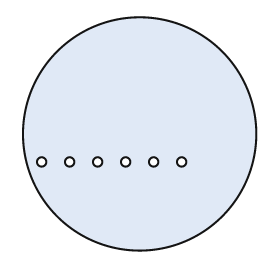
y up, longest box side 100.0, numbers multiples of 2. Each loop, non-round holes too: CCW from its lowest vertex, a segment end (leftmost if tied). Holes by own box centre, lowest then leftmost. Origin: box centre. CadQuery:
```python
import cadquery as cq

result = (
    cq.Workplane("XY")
    .moveTo(0.0, 0.0)
    .circle(50.0)
    .moveTo(-42.0, -12.0)
    .circle(2.0)
    .moveTo(-30.0, -12.0)
    .circle(2.0)
    .moveTo(-18.0, -12.0)
    .circle(2.0)
    .moveTo(-6.0, -12.0)
    .circle(2.0)
    .moveTo(6.0, -12.0)
    .circle(2.0)
    .moveTo(18.0, -12.0)
    .circle(2.0)
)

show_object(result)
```